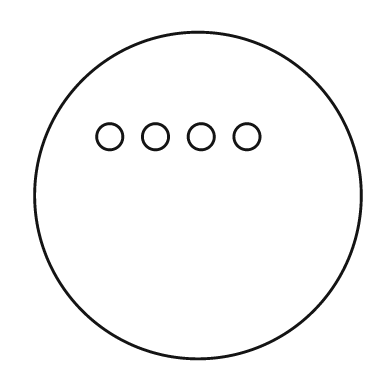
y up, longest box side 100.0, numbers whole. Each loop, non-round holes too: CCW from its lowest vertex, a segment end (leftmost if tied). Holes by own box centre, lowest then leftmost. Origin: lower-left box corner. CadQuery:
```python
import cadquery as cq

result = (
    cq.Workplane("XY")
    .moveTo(50.0, 50.0)
    .circle(50.0)
    .moveTo(23.0, 68.0)
    .circle(4.0)
    .moveTo(37.0, 68.0)
    .circle(4.0)
    .moveTo(51.0, 68.0)
    .circle(4.0)
    .moveTo(65.0, 68.0)
    .circle(4.0)
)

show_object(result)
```